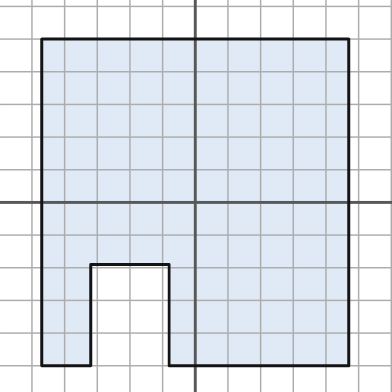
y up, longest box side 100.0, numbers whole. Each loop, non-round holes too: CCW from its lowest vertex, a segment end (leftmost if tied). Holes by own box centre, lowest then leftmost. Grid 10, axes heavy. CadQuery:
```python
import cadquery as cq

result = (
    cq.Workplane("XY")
    .moveTo(-47.0, -50.0)
    .lineTo(-32.0, -50.0)
    .lineTo(-32.0, -19.0)
    .lineTo(-8.0, -19.0)
    .lineTo(-8.0, -50.0)
    .lineTo(47.0, -50.0)
    .lineTo(47.0, 50.0)
    .lineTo(-47.0, 50.0)
    .close()
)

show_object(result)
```